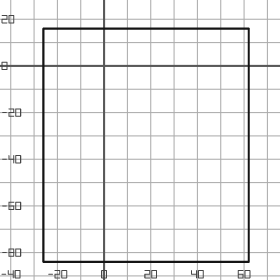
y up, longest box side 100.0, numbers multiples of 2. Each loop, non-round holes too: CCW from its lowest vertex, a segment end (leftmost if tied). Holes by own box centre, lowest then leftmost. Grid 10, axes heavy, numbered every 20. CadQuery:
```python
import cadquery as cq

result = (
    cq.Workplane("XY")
    .moveTo(-26.0, -84.0)
    .lineTo(62.0, -84.0)
    .lineTo(62.0, 16.0)
    .lineTo(-26.0, 16.0)
    .close()
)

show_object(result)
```